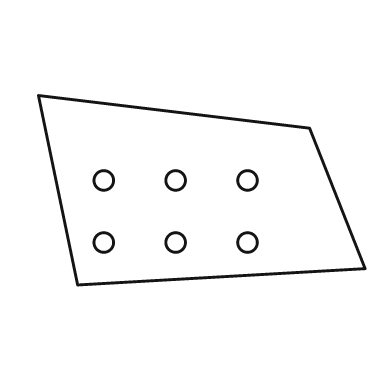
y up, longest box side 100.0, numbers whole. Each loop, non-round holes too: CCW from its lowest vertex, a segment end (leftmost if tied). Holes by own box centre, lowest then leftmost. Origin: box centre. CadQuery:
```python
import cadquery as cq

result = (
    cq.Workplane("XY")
    .moveTo(-38.0, -29.0)
    .lineTo(50.0, -24.0)
    .lineTo(33.0, 19.0)
    .lineTo(-50.0, 29.0)
    .close()
    .moveTo(-30.0, -16.0)
    .circle(3.0)
    .moveTo(-8.0, -16.0)
    .circle(3.0)
    .moveTo(14.0, -16.0)
    .circle(3.0)
    .moveTo(-30.0, 3.0)
    .circle(3.0)
    .moveTo(-8.0, 3.0)
    .circle(3.0)
    .moveTo(14.0, 3.0)
    .circle(3.0)
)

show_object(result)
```